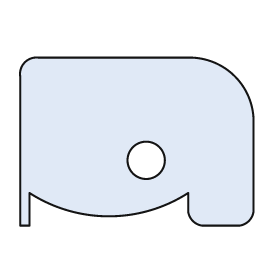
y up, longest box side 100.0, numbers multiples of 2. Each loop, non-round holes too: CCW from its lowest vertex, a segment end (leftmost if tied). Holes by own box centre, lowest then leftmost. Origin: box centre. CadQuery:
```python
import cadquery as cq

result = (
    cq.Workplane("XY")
    .moveTo(-50.0, -36.0)
    .lineTo(-46.0, -36.0)
    .lineTo(-46.0, -22.0)
    .threePointArc((-12.0, -32.0), (22.0, -22.0))
    .lineTo(22.0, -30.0)
    .threePointArc((24.0, -34.0), (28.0, -36.0))
    .lineTo(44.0, -36.0)
    .threePointArc((48.0, -34.0), (50.0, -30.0))
    .lineTo(50.0, 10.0)
    .threePointArc((42.0, 28.0), (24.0, 36.0))
    .lineTo(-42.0, 36.0)
    .threePointArc((-48.0, 34.0), (-50.0, 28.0))
    .close()
    .moveTo(4.0, -8.0)
    .circle(8.0)
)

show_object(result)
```